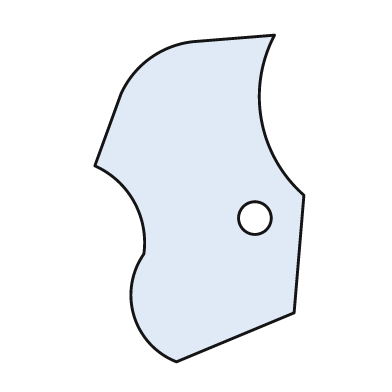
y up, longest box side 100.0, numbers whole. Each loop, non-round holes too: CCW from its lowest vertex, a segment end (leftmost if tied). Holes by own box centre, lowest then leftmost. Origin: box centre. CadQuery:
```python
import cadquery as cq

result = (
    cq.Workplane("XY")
    .moveTo(-7.0, -50.0)
    .lineTo(29.0, -35.0)
    .lineTo(32.0, 1.0)
    .threePointArc((19.0, 24.0), (23.0, 50.0))
    .lineTo(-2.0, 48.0)
    .threePointArc((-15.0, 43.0), (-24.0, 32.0))
    .lineTo(-32.0, 10.0)
    .threePointArc((-20.0, -1.0), (-17.0, -17.0))
    .threePointArc((-20.0, -36.0), (-7.0, -50.0))
    .close()
    .moveTo(17.0, -6.0)
    .circle(5.0)
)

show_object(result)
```